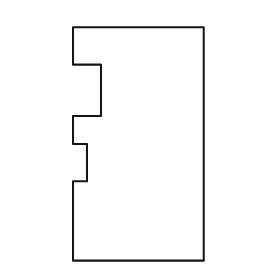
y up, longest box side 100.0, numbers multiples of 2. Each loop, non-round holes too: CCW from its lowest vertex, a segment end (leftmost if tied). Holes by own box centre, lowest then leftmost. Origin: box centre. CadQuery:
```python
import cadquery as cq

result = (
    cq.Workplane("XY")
    .moveTo(-28.0, -50.0)
    .lineTo(28.0, -50.0)
    .lineTo(28.0, 50.0)
    .lineTo(-28.0, 50.0)
    .lineTo(-28.0, 34.0)
    .lineTo(-16.0, 34.0)
    .lineTo(-16.0, 12.0)
    .lineTo(-28.0, 12.0)
    .lineTo(-28.0, 0.0)
    .lineTo(-22.0, 0.0)
    .lineTo(-22.0, -16.0)
    .lineTo(-28.0, -16.0)
    .close()
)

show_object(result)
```